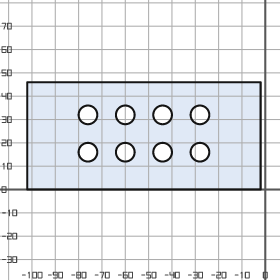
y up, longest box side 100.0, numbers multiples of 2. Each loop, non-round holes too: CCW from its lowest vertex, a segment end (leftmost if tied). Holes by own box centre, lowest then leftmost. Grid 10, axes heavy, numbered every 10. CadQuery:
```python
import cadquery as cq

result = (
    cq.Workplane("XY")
    .moveTo(-102.0, 0.0)
    .lineTo(-2.0, 0.0)
    .lineTo(-2.0, 46.0)
    .lineTo(-102.0, 46.0)
    .close()
    .moveTo(-76.0, 16.0)
    .circle(4.0)
    .moveTo(-60.0, 16.0)
    .circle(4.0)
    .moveTo(-44.0, 16.0)
    .circle(4.0)
    .moveTo(-28.0, 16.0)
    .circle(4.0)
    .moveTo(-76.0, 32.0)
    .circle(4.0)
    .moveTo(-60.0, 32.0)
    .circle(4.0)
    .moveTo(-44.0, 32.0)
    .circle(4.0)
    .moveTo(-28.0, 32.0)
    .circle(4.0)
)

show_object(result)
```